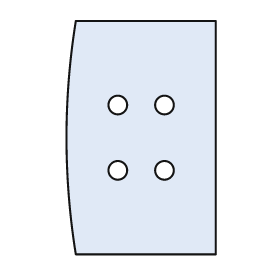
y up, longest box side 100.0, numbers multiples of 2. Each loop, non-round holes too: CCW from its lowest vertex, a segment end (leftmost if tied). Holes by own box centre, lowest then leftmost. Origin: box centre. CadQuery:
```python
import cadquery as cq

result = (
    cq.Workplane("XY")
    .moveTo(-28.0, -50.0)
    .lineTo(32.0, -50.0)
    .lineTo(32.0, 50.0)
    .lineTo(-28.0, 50.0)
    .threePointArc((-32.0, 0.0), (-28.0, -50.0))
    .close()
    .moveTo(-10.0, -14.0)
    .circle(4.0)
    .moveTo(10.0, -14.0)
    .circle(4.0)
    .moveTo(-10.0, 14.0)
    .circle(4.0)
    .moveTo(10.0, 14.0)
    .circle(4.0)
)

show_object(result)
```